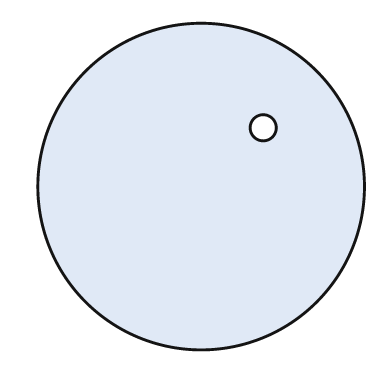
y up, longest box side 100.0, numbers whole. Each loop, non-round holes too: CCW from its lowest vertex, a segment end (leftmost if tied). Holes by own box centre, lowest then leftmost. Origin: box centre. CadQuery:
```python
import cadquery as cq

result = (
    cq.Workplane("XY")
    .moveTo(0.0, 0.0)
    .circle(50.0)
    .moveTo(19.0, 18.0)
    .circle(4.0)
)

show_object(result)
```